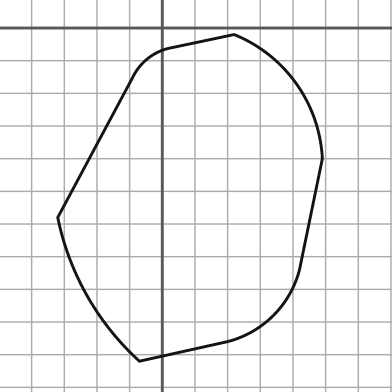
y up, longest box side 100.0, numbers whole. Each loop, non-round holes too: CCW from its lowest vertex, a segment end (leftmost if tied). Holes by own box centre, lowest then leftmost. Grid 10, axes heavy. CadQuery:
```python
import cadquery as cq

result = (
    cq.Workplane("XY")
    .moveTo(-7.0, -102.0)
    .lineTo(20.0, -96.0)
    .threePointArc((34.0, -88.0), (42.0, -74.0))
    .lineTo(49.0, -40.0)
    .threePointArc((41.0, -17.0), (22.0, -2.0))
    .lineTo(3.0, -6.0)
    .threePointArc((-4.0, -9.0), (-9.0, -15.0))
    .lineTo(-32.0, -58.0)
    .threePointArc((-23.0, -82.0), (-7.0, -102.0))
    .close()
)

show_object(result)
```